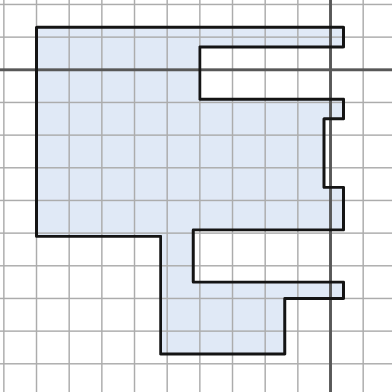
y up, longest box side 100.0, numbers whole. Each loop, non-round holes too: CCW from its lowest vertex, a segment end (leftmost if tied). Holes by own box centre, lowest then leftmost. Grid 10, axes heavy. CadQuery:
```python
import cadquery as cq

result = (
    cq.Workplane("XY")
    .moveTo(-52.0, -87.0)
    .lineTo(-14.0, -87.0)
    .lineTo(-14.0, -70.0)
    .lineTo(4.0, -70.0)
    .lineTo(4.0, -65.0)
    .lineTo(-42.0, -65.0)
    .lineTo(-42.0, -49.0)
    .lineTo(4.0, -49.0)
    .lineTo(4.0, -36.0)
    .lineTo(-2.0, -36.0)
    .lineTo(-2.0, -15.0)
    .lineTo(4.0, -15.0)
    .lineTo(4.0, -9.0)
    .lineTo(-40.0, -9.0)
    .lineTo(-40.0, 7.0)
    .lineTo(4.0, 7.0)
    .lineTo(4.0, 13.0)
    .lineTo(-90.0, 13.0)
    .lineTo(-90.0, -51.0)
    .lineTo(-52.0, -51.0)
    .close()
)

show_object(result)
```